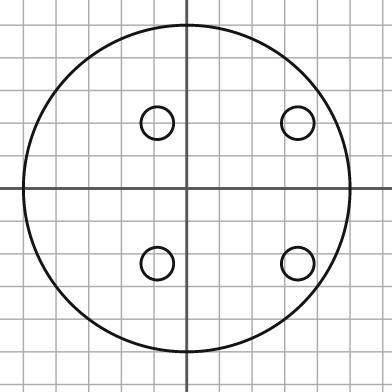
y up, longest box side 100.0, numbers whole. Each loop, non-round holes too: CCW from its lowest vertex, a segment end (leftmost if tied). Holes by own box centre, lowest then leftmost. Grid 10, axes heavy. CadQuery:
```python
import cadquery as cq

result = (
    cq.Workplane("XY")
    .moveTo(0.0, 0.0)
    .circle(50.0)
    .moveTo(-9.0, -23.0)
    .circle(5.0)
    .moveTo(34.0, -23.0)
    .circle(5.0)
    .moveTo(-9.0, 20.0)
    .circle(5.0)
    .moveTo(34.0, 20.0)
    .circle(5.0)
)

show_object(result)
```